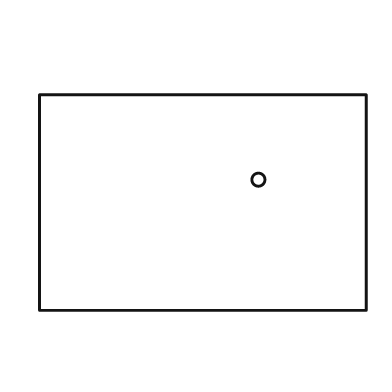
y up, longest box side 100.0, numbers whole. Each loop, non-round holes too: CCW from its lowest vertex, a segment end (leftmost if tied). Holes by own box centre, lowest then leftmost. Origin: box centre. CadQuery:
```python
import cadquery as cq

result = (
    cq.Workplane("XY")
    .moveTo(-50.0, -33.0)
    .lineTo(50.0, -33.0)
    .lineTo(50.0, 33.0)
    .lineTo(-50.0, 33.0)
    .close()
    .moveTo(17.0, 7.0)
    .circle(2.0)
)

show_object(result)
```